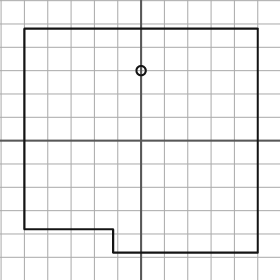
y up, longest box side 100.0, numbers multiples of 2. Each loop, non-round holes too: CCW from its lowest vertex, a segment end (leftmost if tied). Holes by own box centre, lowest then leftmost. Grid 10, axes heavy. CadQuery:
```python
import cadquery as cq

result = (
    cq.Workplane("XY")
    .moveTo(-12.0, -48.0)
    .lineTo(50.0, -48.0)
    .lineTo(50.0, 48.0)
    .lineTo(-50.0, 48.0)
    .lineTo(-50.0, -38.0)
    .lineTo(-12.0, -38.0)
    .close()
    .moveTo(0.0, 30.0)
    .circle(2.0)
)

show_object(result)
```